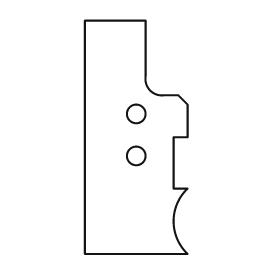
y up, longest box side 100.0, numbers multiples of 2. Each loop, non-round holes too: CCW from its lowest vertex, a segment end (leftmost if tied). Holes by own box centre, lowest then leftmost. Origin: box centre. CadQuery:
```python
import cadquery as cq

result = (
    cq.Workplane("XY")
    .moveTo(-22.0, -50.0)
    .lineTo(22.0, -50.0)
    .threePointArc((16.0, -36.0), (22.0, -22.0))
    .lineTo(16.0, -22.0)
    .lineTo(16.0, 0.0)
    .lineTo(22.0, 0.0)
    .lineTo(22.0, 14.0)
    .lineTo(18.0, 18.0)
    .lineTo(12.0, 18.0)
    .threePointArc((6.0, 20.0), (4.0, 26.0))
    .lineTo(4.0, 50.0)
    .lineTo(-22.0, 50.0)
    .close()
    .moveTo(0.0, -8.0)
    .circle(4.0)
    .moveTo(0.0, 10.0)
    .circle(4.0)
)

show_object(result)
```